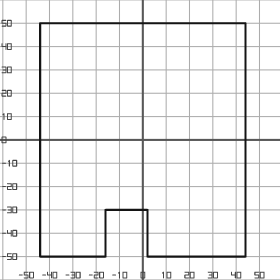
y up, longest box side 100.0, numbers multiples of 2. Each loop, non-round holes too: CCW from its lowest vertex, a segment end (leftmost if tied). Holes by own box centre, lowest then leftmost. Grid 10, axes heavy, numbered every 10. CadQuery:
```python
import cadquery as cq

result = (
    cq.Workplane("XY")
    .moveTo(-44.0, -50.0)
    .lineTo(-16.0, -50.0)
    .lineTo(-16.0, -30.0)
    .lineTo(2.0, -30.0)
    .lineTo(2.0, -50.0)
    .lineTo(44.0, -50.0)
    .lineTo(44.0, 50.0)
    .lineTo(-44.0, 50.0)
    .close()
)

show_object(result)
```